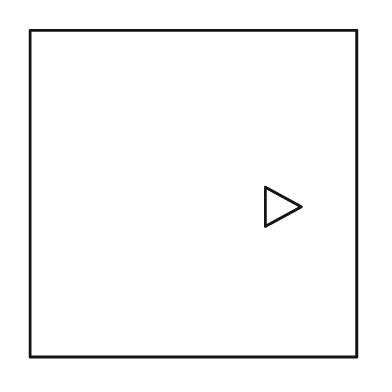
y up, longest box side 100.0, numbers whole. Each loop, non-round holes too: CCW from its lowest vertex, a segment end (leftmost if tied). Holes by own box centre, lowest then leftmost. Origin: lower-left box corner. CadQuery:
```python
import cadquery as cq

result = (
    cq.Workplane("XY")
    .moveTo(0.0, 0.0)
    .lineTo(100.0, 0.0)
    .lineTo(100.0, 100.0)
    .lineTo(0.0, 100.0)
    .close()
    .moveTo(72.0, 40.0)
    .lineTo(83.0, 46.0)
    .lineTo(72.0, 52.0)
    .close()
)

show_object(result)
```